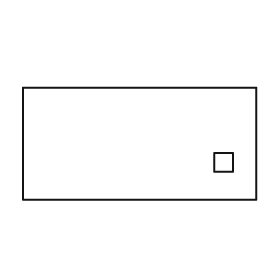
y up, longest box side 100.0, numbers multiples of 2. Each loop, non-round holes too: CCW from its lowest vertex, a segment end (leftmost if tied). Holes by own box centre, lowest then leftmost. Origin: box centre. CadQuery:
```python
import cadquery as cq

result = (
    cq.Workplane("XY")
    .moveTo(-50.0, -24.0)
    .lineTo(50.0, -24.0)
    .lineTo(50.0, 24.0)
    .lineTo(-50.0, 24.0)
    .close()
    .moveTo(32.0, -12.0)
    .lineTo(40.0, -12.0)
    .lineTo(40.0, -4.0)
    .lineTo(32.0, -4.0)
    .close()
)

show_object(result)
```